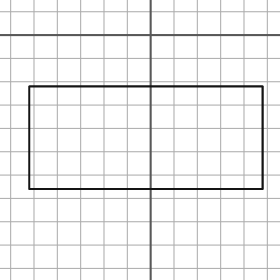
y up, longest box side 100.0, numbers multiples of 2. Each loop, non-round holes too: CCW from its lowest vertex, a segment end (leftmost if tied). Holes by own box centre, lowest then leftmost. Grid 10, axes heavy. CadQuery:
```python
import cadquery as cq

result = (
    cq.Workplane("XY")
    .moveTo(-52.0, -66.0)
    .lineTo(48.0, -66.0)
    .lineTo(48.0, -22.0)
    .lineTo(-52.0, -22.0)
    .close()
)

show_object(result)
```